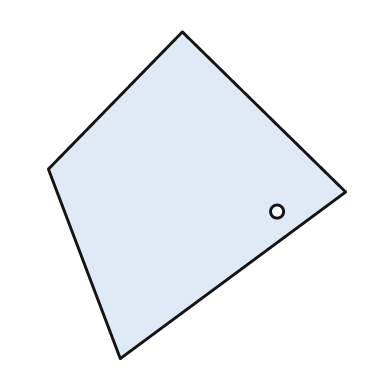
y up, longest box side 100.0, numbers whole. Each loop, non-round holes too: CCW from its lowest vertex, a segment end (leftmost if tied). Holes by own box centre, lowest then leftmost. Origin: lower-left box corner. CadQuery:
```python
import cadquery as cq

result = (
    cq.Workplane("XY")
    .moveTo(22.0, 0.0)
    .lineTo(91.0, 51.0)
    .lineTo(41.0, 100.0)
    .lineTo(0.0, 58.0)
    .close()
    .moveTo(70.0, 45.0)
    .circle(2.0)
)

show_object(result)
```